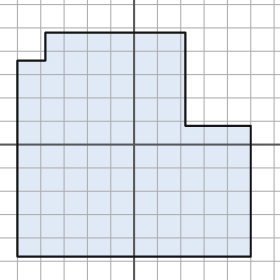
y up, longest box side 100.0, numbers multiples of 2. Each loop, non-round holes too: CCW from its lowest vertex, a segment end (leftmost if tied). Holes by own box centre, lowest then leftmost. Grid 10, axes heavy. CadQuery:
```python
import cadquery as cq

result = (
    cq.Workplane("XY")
    .moveTo(-50.0, -48.0)
    .lineTo(50.0, -48.0)
    .lineTo(50.0, 8.0)
    .lineTo(22.0, 8.0)
    .lineTo(22.0, 48.0)
    .lineTo(-38.0, 48.0)
    .lineTo(-38.0, 36.0)
    .lineTo(-50.0, 36.0)
    .close()
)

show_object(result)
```